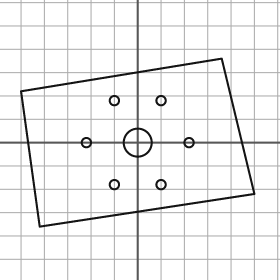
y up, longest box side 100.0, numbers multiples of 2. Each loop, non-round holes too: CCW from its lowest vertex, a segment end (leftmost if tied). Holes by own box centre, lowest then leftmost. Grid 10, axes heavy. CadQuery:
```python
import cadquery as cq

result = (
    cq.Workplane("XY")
    .moveTo(-42.0, -36.0)
    .lineTo(50.0, -22.0)
    .lineTo(36.0, 36.0)
    .lineTo(-50.0, 22.0)
    .close()
    .moveTo(-10.0, -18.0)
    .circle(2.0)
    .moveTo(10.0, -18.0)
    .circle(2.0)
    .moveTo(-22.0, 0.0)
    .circle(2.0)
    .moveTo(0.0, 0.0)
    .circle(6.0)
    .moveTo(22.0, 0.0)
    .circle(2.0)
    .moveTo(-10.0, 18.0)
    .circle(2.0)
    .moveTo(10.0, 18.0)
    .circle(2.0)
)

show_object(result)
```